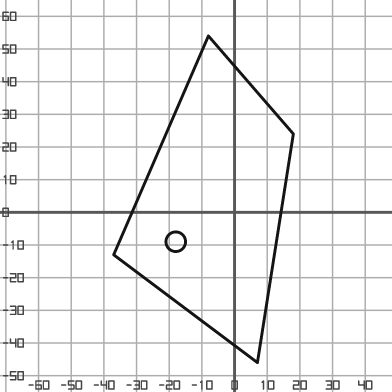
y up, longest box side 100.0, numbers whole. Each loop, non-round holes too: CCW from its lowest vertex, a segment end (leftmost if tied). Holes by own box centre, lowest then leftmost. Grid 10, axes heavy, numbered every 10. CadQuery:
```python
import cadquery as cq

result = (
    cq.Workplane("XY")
    .moveTo(7.0, -46.0)
    .lineTo(18.0, 24.0)
    .lineTo(-8.0, 54.0)
    .lineTo(-37.0, -13.0)
    .close()
    .moveTo(-18.0, -9.0)
    .circle(3.0)
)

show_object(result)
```